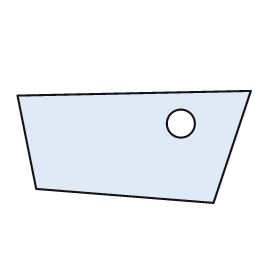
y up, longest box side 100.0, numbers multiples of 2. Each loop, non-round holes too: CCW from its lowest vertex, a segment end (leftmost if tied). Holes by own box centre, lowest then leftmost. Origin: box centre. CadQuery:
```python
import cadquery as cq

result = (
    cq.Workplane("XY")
    .moveTo(34.0, -24.0)
    .lineTo(50.0, 24.0)
    .lineTo(-50.0, 22.0)
    .lineTo(-42.0, -18.0)
    .close()
    .moveTo(20.0, 10.0)
    .circle(6.0)
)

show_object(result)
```